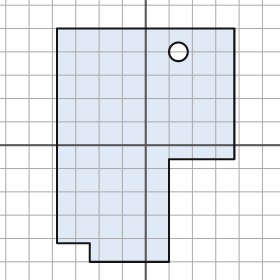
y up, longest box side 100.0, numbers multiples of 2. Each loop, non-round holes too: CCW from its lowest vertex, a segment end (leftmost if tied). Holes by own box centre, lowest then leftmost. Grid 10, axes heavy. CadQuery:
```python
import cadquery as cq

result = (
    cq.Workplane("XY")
    .moveTo(-24.0, -50.0)
    .lineTo(10.0, -50.0)
    .lineTo(10.0, -6.0)
    .lineTo(38.0, -6.0)
    .lineTo(38.0, 50.0)
    .lineTo(-38.0, 50.0)
    .lineTo(-38.0, -42.0)
    .lineTo(-24.0, -42.0)
    .close()
    .moveTo(14.0, 40.0)
    .circle(4.0)
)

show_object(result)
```